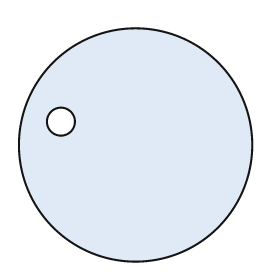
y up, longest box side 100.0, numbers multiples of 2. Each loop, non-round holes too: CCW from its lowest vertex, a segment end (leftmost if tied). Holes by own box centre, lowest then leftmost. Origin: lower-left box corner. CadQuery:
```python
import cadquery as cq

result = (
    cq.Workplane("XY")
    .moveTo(50.0, 50.0)
    .circle(50.0)
    .moveTo(18.0, 60.0)
    .circle(6.0)
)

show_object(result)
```